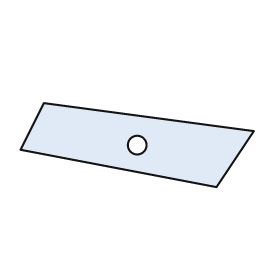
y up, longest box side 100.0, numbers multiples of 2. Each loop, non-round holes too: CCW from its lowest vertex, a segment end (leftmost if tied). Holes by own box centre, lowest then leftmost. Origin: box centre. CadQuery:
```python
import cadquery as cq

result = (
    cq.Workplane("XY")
    .moveTo(34.0, -18.0)
    .lineTo(50.0, 6.0)
    .lineTo(-40.0, 18.0)
    .lineTo(-50.0, -2.0)
    .close()
    .moveTo(0.0, 0.0)
    .circle(4.0)
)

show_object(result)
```